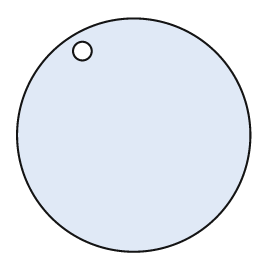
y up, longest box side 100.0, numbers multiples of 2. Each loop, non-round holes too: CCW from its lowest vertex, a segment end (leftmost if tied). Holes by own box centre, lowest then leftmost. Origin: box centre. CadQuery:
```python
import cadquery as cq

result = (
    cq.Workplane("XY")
    .moveTo(0.0, 0.0)
    .circle(50.0)
    .moveTo(-22.0, 36.0)
    .circle(4.0)
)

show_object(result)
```